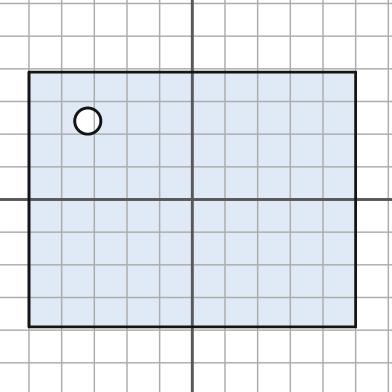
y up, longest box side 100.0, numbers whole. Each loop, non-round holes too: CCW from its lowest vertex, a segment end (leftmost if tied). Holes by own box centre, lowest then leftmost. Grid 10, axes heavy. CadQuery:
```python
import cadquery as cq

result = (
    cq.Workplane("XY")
    .moveTo(-50.0, -39.0)
    .lineTo(50.0, -39.0)
    .lineTo(50.0, 39.0)
    .lineTo(-50.0, 39.0)
    .close()
    .moveTo(-32.0, 24.0)
    .circle(4.0)
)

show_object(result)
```